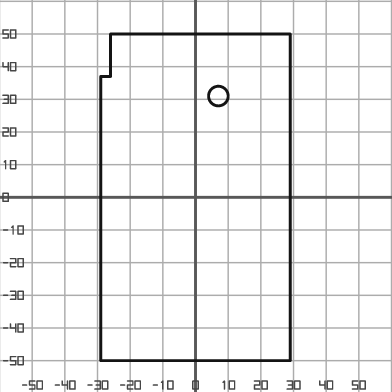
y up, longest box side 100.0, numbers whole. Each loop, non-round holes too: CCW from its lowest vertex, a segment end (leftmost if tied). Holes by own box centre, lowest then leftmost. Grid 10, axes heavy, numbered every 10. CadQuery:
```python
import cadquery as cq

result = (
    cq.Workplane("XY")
    .moveTo(-29.0, -50.0)
    .lineTo(29.0, -50.0)
    .lineTo(29.0, 50.0)
    .lineTo(-26.0, 50.0)
    .lineTo(-26.0, 37.0)
    .lineTo(-29.0, 37.0)
    .close()
    .moveTo(7.0, 31.0)
    .circle(3.0)
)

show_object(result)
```